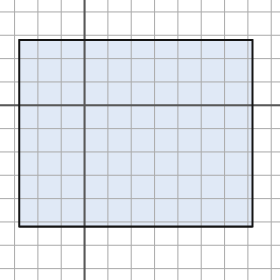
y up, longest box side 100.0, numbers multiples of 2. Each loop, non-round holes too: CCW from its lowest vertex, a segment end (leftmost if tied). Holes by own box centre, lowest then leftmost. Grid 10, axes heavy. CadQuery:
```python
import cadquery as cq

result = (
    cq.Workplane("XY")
    .moveTo(-28.0, -52.0)
    .lineTo(72.0, -52.0)
    .lineTo(72.0, 28.0)
    .lineTo(-28.0, 28.0)
    .close()
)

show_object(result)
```